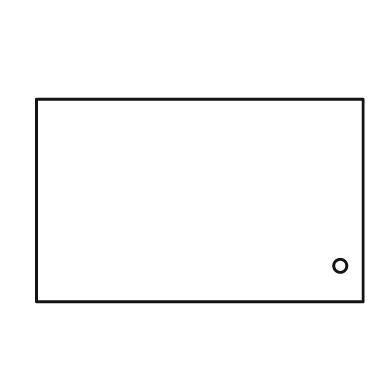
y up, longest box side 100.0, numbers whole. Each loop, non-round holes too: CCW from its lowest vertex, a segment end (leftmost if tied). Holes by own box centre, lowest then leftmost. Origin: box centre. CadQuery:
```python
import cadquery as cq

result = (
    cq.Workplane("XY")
    .moveTo(-50.0, -31.0)
    .lineTo(50.0, -31.0)
    .lineTo(50.0, 31.0)
    .lineTo(-50.0, 31.0)
    .close()
    .moveTo(43.0, -20.0)
    .circle(2.0)
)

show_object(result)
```